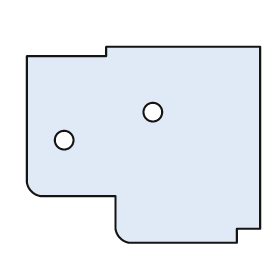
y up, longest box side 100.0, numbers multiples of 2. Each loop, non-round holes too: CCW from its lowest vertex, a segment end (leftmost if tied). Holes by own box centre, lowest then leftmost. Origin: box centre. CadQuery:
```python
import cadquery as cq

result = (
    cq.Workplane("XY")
    .moveTo(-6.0, -42.0)
    .lineTo(40.0, -42.0)
    .lineTo(40.0, -36.0)
    .lineTo(50.0, -36.0)
    .lineTo(50.0, 42.0)
    .lineTo(-16.0, 42.0)
    .lineTo(-16.0, 38.0)
    .lineTo(-50.0, 38.0)
    .lineTo(-50.0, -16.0)
    .threePointArc((-48.0, -20.0), (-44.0, -22.0))
    .lineTo(-12.0, -22.0)
    .lineTo(-12.0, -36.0)
    .threePointArc((-10.0, -40.0), (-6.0, -42.0))
    .close()
    .moveTo(-34.0, 2.0)
    .circle(4.0)
    .moveTo(4.0, 14.0)
    .circle(4.0)
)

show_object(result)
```